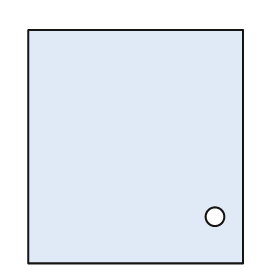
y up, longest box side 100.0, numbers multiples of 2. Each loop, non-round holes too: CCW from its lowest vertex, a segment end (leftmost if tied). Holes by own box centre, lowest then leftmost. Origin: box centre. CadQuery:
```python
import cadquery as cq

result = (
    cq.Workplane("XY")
    .moveTo(-46.0, -50.0)
    .lineTo(46.0, -50.0)
    .lineTo(46.0, 50.0)
    .lineTo(-46.0, 50.0)
    .close()
    .moveTo(34.0, -30.0)
    .circle(4.0)
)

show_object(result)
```